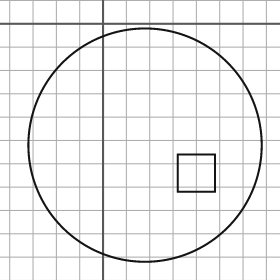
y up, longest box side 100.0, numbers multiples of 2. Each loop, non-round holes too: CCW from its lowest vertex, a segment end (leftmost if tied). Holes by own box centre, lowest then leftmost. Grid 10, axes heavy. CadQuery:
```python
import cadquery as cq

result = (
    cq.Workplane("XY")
    .moveTo(18.0, -52.0)
    .circle(50.0)
    .moveTo(32.0, -72.0)
    .lineTo(48.0, -72.0)
    .lineTo(48.0, -56.0)
    .lineTo(32.0, -56.0)
    .close()
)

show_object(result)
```